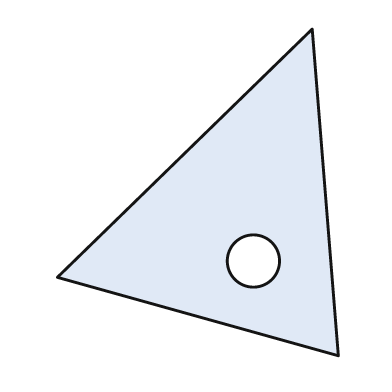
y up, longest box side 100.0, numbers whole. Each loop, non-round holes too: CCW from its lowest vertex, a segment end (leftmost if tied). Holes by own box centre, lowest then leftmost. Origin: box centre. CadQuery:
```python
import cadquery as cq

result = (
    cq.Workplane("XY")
    .moveTo(43.0, -50.0)
    .lineTo(35.0, 50.0)
    .lineTo(-43.0, -26.0)
    .close()
    .moveTo(17.0, -21.0)
    .circle(8.0)
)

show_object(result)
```